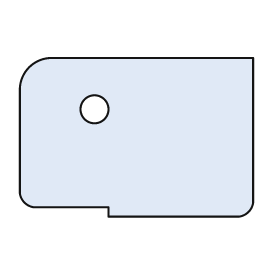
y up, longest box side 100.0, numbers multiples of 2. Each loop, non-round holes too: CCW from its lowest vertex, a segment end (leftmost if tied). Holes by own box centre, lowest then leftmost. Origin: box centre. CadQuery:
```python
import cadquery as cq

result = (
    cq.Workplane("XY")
    .moveTo(-12.0, -34.0)
    .lineTo(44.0, -34.0)
    .threePointArc((48.0, -32.0), (50.0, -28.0))
    .lineTo(50.0, 34.0)
    .lineTo(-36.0, 34.0)
    .threePointArc((-46.0, 30.0), (-50.0, 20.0))
    .lineTo(-50.0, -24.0)
    .threePointArc((-48.0, -28.0), (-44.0, -30.0))
    .lineTo(-12.0, -30.0)
    .close()
    .moveTo(-18.0, 12.0)
    .circle(6.0)
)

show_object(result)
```